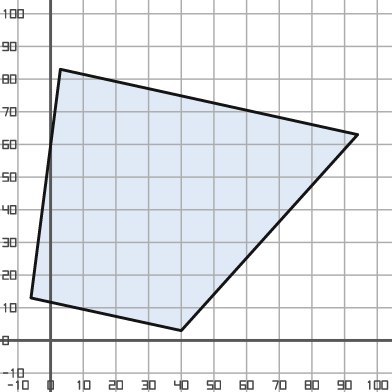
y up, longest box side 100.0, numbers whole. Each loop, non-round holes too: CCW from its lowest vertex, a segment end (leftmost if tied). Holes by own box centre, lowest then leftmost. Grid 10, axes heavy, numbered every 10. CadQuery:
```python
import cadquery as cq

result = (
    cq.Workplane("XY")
    .moveTo(40.0, 3.0)
    .lineTo(94.0, 63.0)
    .lineTo(3.0, 83.0)
    .lineTo(-6.0, 13.0)
    .close()
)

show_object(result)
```